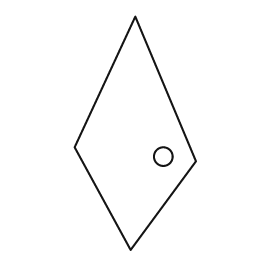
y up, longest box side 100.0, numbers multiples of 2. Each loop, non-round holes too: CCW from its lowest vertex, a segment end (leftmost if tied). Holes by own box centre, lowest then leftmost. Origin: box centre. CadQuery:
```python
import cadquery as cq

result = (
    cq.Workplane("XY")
    .moveTo(-2.0, -50.0)
    .lineTo(26.0, -12.0)
    .lineTo(0.0, 50.0)
    .lineTo(-26.0, -6.0)
    .close()
    .moveTo(12.0, -10.0)
    .circle(4.0)
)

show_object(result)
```